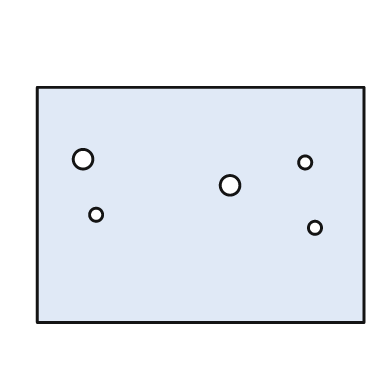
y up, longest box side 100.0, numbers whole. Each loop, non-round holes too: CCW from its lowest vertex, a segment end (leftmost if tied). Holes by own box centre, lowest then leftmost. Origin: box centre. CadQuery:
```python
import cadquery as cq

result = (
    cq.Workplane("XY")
    .moveTo(-50.0, -36.0)
    .lineTo(50.0, -36.0)
    .lineTo(50.0, 36.0)
    .lineTo(-50.0, 36.0)
    .close()
    .moveTo(35.0, -7.0)
    .circle(2.0)
    .moveTo(-32.0, -3.0)
    .circle(2.0)
    .moveTo(9.0, 6.0)
    .circle(3.0)
    .moveTo(32.0, 13.0)
    .circle(2.0)
    .moveTo(-36.0, 14.0)
    .circle(3.0)
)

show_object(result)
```